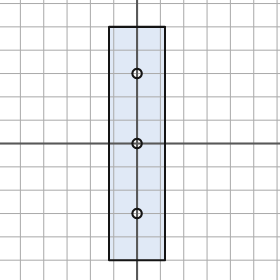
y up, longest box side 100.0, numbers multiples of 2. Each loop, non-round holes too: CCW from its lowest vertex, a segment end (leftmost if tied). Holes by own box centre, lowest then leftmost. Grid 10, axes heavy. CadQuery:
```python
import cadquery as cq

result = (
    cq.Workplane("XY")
    .moveTo(-12.0, -50.0)
    .lineTo(12.0, -50.0)
    .lineTo(12.0, 50.0)
    .lineTo(-12.0, 50.0)
    .close()
    .moveTo(0.0, -30.0)
    .circle(2.0)
    .moveTo(0.0, 0.0)
    .circle(2.0)
    .moveTo(0.0, 30.0)
    .circle(2.0)
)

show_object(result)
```